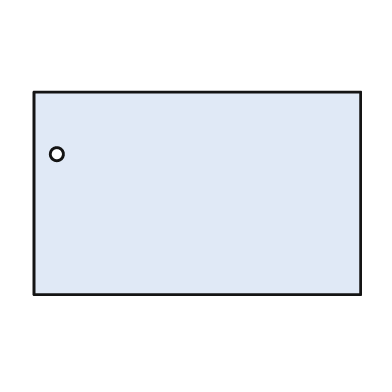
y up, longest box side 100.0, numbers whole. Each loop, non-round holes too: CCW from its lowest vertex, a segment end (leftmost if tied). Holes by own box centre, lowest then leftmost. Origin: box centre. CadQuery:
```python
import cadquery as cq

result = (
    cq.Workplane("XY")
    .moveTo(-50.0, -31.0)
    .lineTo(50.0, -31.0)
    .lineTo(50.0, 31.0)
    .lineTo(-50.0, 31.0)
    .close()
    .moveTo(-43.0, 12.0)
    .circle(2.0)
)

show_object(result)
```